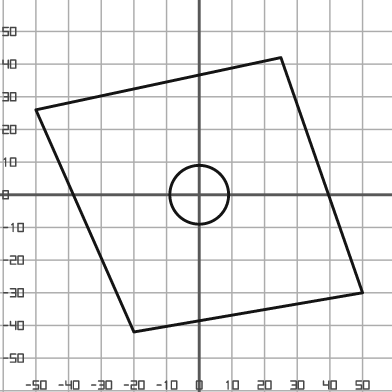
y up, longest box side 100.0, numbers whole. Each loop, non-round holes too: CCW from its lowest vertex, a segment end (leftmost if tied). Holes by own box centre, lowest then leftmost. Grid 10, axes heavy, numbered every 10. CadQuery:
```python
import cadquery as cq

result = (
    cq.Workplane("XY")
    .moveTo(-20.0, -42.0)
    .lineTo(50.0, -30.0)
    .lineTo(25.0, 42.0)
    .lineTo(-50.0, 26.0)
    .close()
    .moveTo(0.0, 0.0)
    .circle(9.0)
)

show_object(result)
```